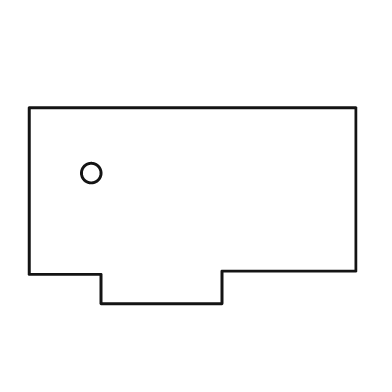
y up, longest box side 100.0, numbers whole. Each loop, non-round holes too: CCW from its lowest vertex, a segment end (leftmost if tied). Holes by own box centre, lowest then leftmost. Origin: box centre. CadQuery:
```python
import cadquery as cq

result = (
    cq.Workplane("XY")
    .moveTo(-28.0, -30.0)
    .lineTo(9.0, -30.0)
    .lineTo(9.0, -20.0)
    .lineTo(50.0, -20.0)
    .lineTo(50.0, 30.0)
    .lineTo(-50.0, 30.0)
    .lineTo(-50.0, -21.0)
    .lineTo(-28.0, -21.0)
    .close()
    .moveTo(-31.0, 10.0)
    .circle(3.0)
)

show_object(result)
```